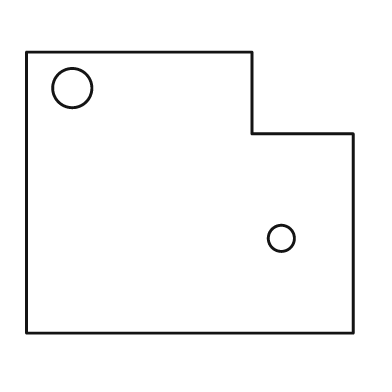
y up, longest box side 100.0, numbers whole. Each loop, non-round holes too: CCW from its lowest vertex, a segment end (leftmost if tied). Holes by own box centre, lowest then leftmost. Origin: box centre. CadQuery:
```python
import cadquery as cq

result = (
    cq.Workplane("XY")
    .moveTo(-50.0, -43.0)
    .lineTo(50.0, -43.0)
    .lineTo(50.0, 18.0)
    .lineTo(19.0, 18.0)
    .lineTo(19.0, 43.0)
    .lineTo(-50.0, 43.0)
    .close()
    .moveTo(28.0, -14.0)
    .circle(4.0)
    .moveTo(-36.0, 32.0)
    .circle(6.0)
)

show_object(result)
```